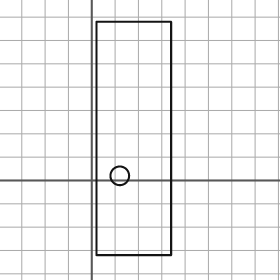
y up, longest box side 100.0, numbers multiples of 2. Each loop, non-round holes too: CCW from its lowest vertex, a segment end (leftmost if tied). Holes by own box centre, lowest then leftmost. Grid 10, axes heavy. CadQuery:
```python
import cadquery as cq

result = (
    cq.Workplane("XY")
    .moveTo(2.0, -32.0)
    .lineTo(34.0, -32.0)
    .lineTo(34.0, 68.0)
    .lineTo(2.0, 68.0)
    .close()
    .moveTo(12.0, 2.0)
    .circle(4.0)
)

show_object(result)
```